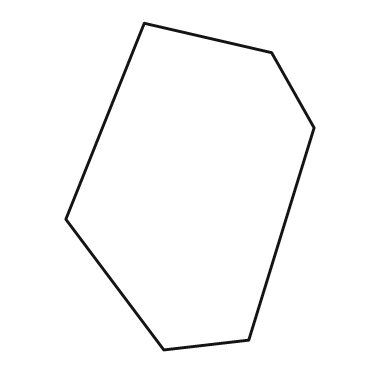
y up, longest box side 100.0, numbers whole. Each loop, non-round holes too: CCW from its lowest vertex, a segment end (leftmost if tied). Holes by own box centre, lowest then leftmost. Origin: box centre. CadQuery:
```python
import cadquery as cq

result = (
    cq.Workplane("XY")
    .moveTo(-8.0, -50.0)
    .lineTo(18.0, -47.0)
    .lineTo(38.0, 18.0)
    .lineTo(25.0, 41.0)
    .lineTo(-14.0, 50.0)
    .lineTo(-38.0, -10.0)
    .close()
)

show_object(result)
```